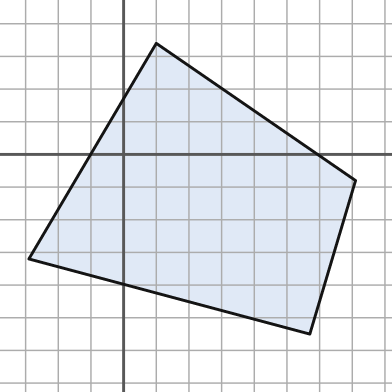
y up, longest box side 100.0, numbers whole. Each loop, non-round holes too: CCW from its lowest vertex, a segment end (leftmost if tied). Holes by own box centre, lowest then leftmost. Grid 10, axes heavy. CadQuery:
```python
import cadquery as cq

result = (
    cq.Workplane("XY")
    .moveTo(57.0, -55.0)
    .lineTo(71.0, -8.0)
    .lineTo(10.0, 34.0)
    .lineTo(-29.0, -32.0)
    .close()
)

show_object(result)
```